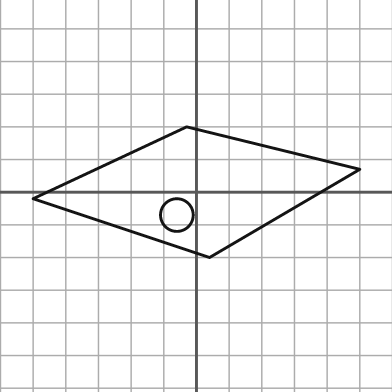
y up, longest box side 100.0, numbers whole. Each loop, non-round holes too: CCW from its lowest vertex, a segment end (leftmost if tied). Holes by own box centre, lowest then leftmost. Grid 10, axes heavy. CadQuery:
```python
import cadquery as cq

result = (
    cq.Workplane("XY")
    .moveTo(4.0, -20.0)
    .lineTo(50.0, 7.0)
    .lineTo(-3.0, 20.0)
    .lineTo(-50.0, -2.0)
    .close()
    .moveTo(-6.0, -7.0)
    .circle(5.0)
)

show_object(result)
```